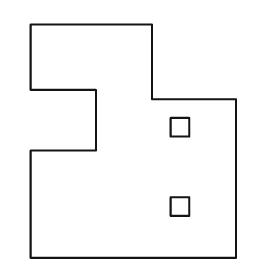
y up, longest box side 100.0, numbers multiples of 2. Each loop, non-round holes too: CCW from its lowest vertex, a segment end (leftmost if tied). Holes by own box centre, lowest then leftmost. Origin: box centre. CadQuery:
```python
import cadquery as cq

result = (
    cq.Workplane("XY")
    .moveTo(-44.0, -50.0)
    .lineTo(44.0, -50.0)
    .lineTo(44.0, 18.0)
    .lineTo(8.0, 18.0)
    .lineTo(8.0, 50.0)
    .lineTo(-44.0, 50.0)
    .lineTo(-44.0, 22.0)
    .lineTo(-16.0, 22.0)
    .lineTo(-16.0, -4.0)
    .lineTo(-44.0, -4.0)
    .close()
    .moveTo(16.0, -32.0)
    .lineTo(24.0, -32.0)
    .lineTo(24.0, -24.0)
    .lineTo(16.0, -24.0)
    .close()
    .moveTo(16.0, 2.0)
    .lineTo(24.0, 2.0)
    .lineTo(24.0, 10.0)
    .lineTo(16.0, 10.0)
    .close()
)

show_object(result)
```